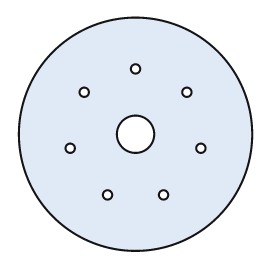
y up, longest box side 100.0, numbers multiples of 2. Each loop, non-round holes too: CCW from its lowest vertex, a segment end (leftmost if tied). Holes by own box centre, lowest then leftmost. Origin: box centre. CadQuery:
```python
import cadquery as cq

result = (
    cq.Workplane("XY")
    .moveTo(0.0, 0.0)
    .circle(50.0)
    .moveTo(-12.0, -26.0)
    .circle(2.0)
    .moveTo(12.0, -26.0)
    .circle(2.0)
    .moveTo(-28.0, -6.0)
    .circle(2.0)
    .moveTo(28.0, -6.0)
    .circle(2.0)
    .moveTo(0.0, 0.0)
    .circle(8.0)
    .moveTo(-22.0, 18.0)
    .circle(2.0)
    .moveTo(22.0, 18.0)
    .circle(2.0)
    .moveTo(0.0, 28.0)
    .circle(2.0)
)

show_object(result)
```